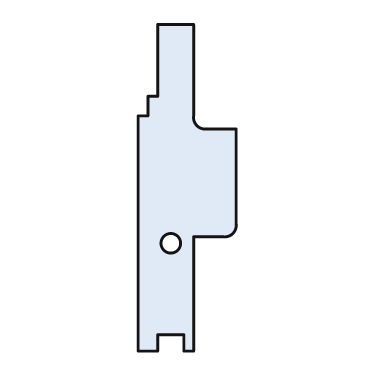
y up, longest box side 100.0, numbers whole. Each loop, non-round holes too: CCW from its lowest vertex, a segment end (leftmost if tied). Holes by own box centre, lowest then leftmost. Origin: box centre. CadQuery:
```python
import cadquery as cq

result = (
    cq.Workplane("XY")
    .moveTo(-15.0, -50.0)
    .lineTo(-9.0, -50.0)
    .lineTo(-9.0, -45.0)
    .lineTo(-1.0, -45.0)
    .lineTo(-1.0, -50.0)
    .lineTo(2.0, -50.0)
    .lineTo(2.0, -15.0)
    .lineTo(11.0, -15.0)
    .threePointArc((14.0, -14.0), (15.0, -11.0))
    .lineTo(15.0, 18.0)
    .lineTo(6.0, 18.0)
    .threePointArc((3.0, 19.0), (2.0, 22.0))
    .lineTo(2.0, 50.0)
    .lineTo(-9.0, 50.0)
    .lineTo(-9.0, 28.0)
    .lineTo(-12.0, 28.0)
    .lineTo(-12.0, 22.0)
    .lineTo(-15.0, 22.0)
    .close()
    .moveTo(-5.0, -17.0)
    .circle(3.0)
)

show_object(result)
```